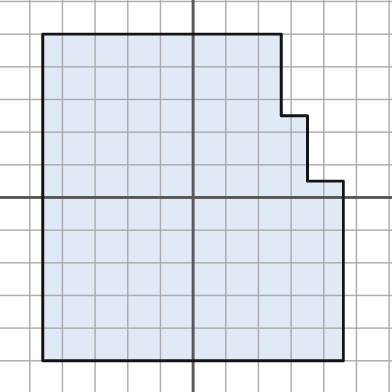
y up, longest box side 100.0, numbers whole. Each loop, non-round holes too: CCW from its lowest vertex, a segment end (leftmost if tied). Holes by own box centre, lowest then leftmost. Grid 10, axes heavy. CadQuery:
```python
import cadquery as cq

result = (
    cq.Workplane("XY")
    .moveTo(-46.0, -50.0)
    .lineTo(46.0, -50.0)
    .lineTo(46.0, 5.0)
    .lineTo(35.0, 5.0)
    .lineTo(35.0, 25.0)
    .lineTo(27.0, 25.0)
    .lineTo(27.0, 50.0)
    .lineTo(-46.0, 50.0)
    .close()
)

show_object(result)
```